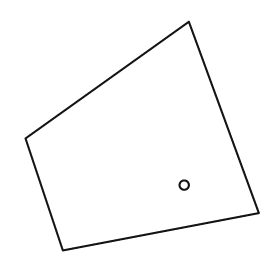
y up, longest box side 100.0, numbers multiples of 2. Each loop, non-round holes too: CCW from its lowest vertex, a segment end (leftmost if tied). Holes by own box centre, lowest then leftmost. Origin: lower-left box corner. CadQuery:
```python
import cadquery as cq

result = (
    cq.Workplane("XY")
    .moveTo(16.0, 0.0)
    .lineTo(100.0, 16.0)
    .lineTo(70.0, 98.0)
    .lineTo(0.0, 48.0)
    .close()
    .moveTo(68.0, 28.0)
    .circle(2.0)
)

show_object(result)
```